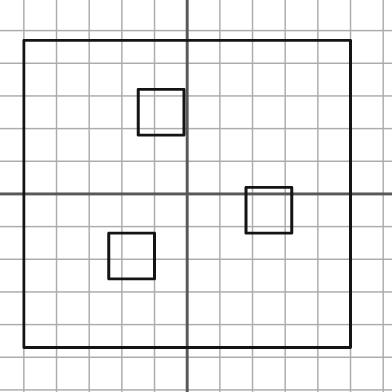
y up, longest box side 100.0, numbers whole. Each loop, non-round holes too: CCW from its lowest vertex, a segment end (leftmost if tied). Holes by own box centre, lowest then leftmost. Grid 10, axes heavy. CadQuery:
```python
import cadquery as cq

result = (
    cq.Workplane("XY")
    .moveTo(-50.0, -47.0)
    .lineTo(50.0, -47.0)
    .lineTo(50.0, 47.0)
    .lineTo(-50.0, 47.0)
    .close()
    .moveTo(-24.0, -26.0)
    .lineTo(-10.0, -26.0)
    .lineTo(-10.0, -12.0)
    .lineTo(-24.0, -12.0)
    .close()
    .moveTo(18.0, -12.0)
    .lineTo(32.0, -12.0)
    .lineTo(32.0, 2.0)
    .lineTo(18.0, 2.0)
    .close()
    .moveTo(-15.0, 18.0)
    .lineTo(-1.0, 18.0)
    .lineTo(-1.0, 32.0)
    .lineTo(-15.0, 32.0)
    .close()
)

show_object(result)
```